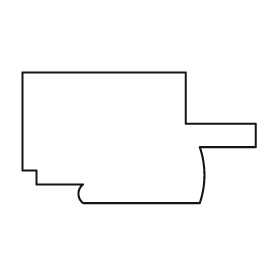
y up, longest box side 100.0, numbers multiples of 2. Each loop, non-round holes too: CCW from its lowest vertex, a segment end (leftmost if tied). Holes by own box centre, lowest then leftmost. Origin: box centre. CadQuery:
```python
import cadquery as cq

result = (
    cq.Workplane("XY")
    .moveTo(-24.0, -28.0)
    .lineTo(26.0, -28.0)
    .threePointArc((28.0, -16.0), (26.0, -4.0))
    .lineTo(50.0, -4.0)
    .lineTo(50.0, 6.0)
    .lineTo(20.0, 6.0)
    .lineTo(20.0, 28.0)
    .lineTo(-50.0, 28.0)
    .lineTo(-50.0, -14.0)
    .lineTo(-44.0, -14.0)
    .lineTo(-44.0, -20.0)
    .lineTo(-24.0, -20.0)
    .threePointArc((-26.0, -24.0), (-24.0, -28.0))
    .close()
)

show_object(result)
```